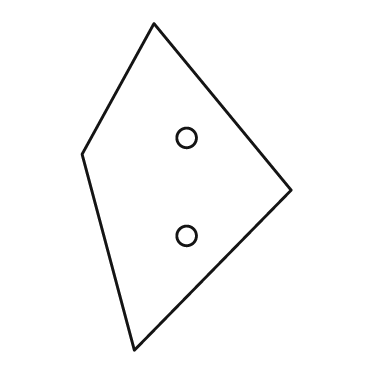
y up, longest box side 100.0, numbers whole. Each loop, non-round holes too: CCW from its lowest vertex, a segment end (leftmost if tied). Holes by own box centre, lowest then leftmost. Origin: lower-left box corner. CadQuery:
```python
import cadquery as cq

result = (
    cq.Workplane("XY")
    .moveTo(16.0, 0.0)
    .lineTo(64.0, 49.0)
    .lineTo(22.0, 100.0)
    .lineTo(0.0, 60.0)
    .close()
    .moveTo(32.0, 35.0)
    .circle(3.0)
    .moveTo(32.0, 65.0)
    .circle(3.0)
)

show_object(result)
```